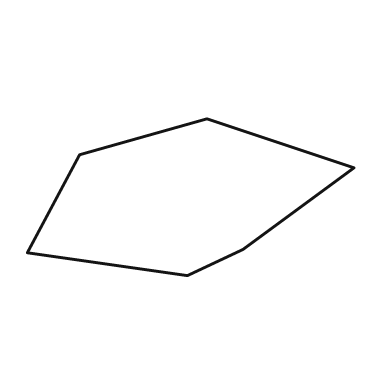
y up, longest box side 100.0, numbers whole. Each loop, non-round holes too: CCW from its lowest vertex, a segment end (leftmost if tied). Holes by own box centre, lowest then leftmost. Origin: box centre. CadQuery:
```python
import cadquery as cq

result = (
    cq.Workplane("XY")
    .moveTo(-1.0, -24.0)
    .lineTo(16.0, -16.0)
    .lineTo(50.0, 9.0)
    .lineTo(5.0, 24.0)
    .lineTo(-34.0, 13.0)
    .lineTo(-50.0, -17.0)
    .close()
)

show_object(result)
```